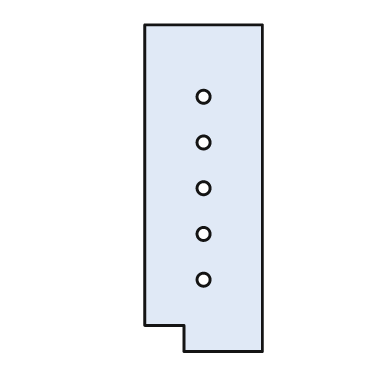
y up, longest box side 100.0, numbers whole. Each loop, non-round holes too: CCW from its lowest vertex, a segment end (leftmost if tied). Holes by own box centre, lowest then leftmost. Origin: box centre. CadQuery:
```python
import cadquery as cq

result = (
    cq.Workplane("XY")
    .moveTo(-6.0, -50.0)
    .lineTo(18.0, -50.0)
    .lineTo(18.0, 50.0)
    .lineTo(-18.0, 50.0)
    .lineTo(-18.0, -42.0)
    .lineTo(-6.0, -42.0)
    .close()
    .moveTo(0.0, -28.0)
    .circle(2.0)
    .moveTo(0.0, -14.0)
    .circle(2.0)
    .moveTo(0.0, 0.0)
    .circle(2.0)
    .moveTo(0.0, 14.0)
    .circle(2.0)
    .moveTo(0.0, 28.0)
    .circle(2.0)
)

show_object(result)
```